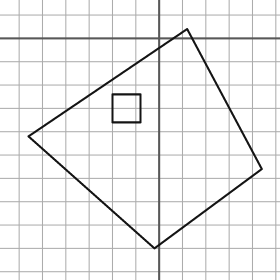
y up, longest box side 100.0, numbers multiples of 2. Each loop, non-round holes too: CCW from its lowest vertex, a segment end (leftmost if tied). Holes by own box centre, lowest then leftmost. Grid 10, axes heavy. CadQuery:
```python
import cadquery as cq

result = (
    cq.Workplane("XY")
    .moveTo(-2.0, -90.0)
    .lineTo(44.0, -56.0)
    .lineTo(12.0, 4.0)
    .lineTo(-56.0, -42.0)
    .close()
    .moveTo(-20.0, -36.0)
    .lineTo(-8.0, -36.0)
    .lineTo(-8.0, -24.0)
    .lineTo(-20.0, -24.0)
    .close()
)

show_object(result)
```